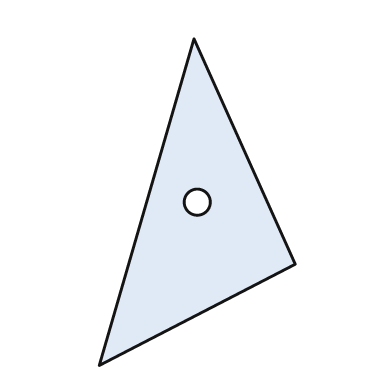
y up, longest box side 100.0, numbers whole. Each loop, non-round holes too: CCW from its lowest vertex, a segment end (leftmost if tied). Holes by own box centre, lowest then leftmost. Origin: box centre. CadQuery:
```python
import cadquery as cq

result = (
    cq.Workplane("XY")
    .moveTo(-30.0, -50.0)
    .lineTo(30.0, -19.0)
    .lineTo(-1.0, 50.0)
    .close()
    .moveTo(0.0, 0.0)
    .circle(4.0)
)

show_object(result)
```